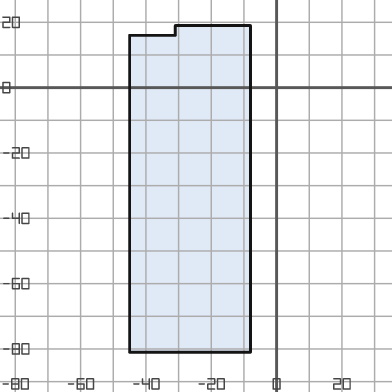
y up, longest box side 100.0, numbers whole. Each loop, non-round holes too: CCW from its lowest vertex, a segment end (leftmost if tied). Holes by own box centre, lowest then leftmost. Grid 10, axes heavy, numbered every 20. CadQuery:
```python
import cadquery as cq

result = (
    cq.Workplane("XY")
    .moveTo(-45.0, -81.0)
    .lineTo(-8.0, -81.0)
    .lineTo(-8.0, 19.0)
    .lineTo(-31.0, 19.0)
    .lineTo(-31.0, 16.0)
    .lineTo(-45.0, 16.0)
    .close()
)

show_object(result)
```